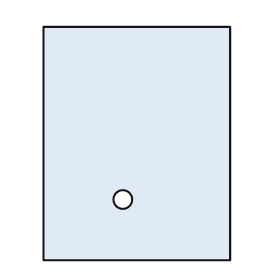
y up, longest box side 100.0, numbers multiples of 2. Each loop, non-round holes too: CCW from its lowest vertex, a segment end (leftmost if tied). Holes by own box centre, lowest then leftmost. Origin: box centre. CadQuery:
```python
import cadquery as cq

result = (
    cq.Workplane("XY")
    .moveTo(-40.0, -50.0)
    .lineTo(40.0, -50.0)
    .lineTo(40.0, 50.0)
    .lineTo(-40.0, 50.0)
    .close()
    .moveTo(-6.0, -24.0)
    .circle(4.0)
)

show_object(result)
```